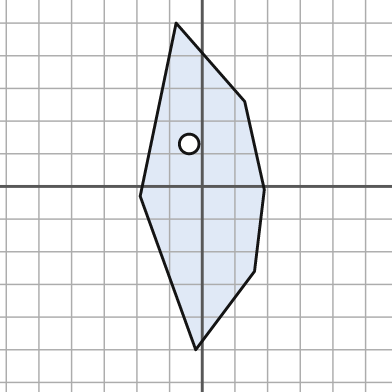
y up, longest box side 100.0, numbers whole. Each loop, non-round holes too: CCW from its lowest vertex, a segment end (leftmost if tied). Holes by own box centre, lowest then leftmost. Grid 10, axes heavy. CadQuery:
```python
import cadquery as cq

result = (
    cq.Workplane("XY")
    .moveTo(-2.0, -50.0)
    .lineTo(16.0, -26.0)
    .lineTo(19.0, -1.0)
    .lineTo(13.0, 26.0)
    .lineTo(-8.0, 50.0)
    .lineTo(-19.0, -3.0)
    .close()
    .moveTo(-4.0, 13.0)
    .circle(3.0)
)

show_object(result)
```